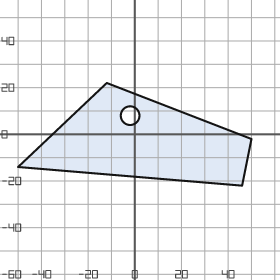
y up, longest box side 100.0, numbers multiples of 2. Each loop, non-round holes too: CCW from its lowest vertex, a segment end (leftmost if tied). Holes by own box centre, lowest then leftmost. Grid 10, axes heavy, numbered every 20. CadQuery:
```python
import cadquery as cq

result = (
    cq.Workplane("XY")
    .moveTo(46.0, -22.0)
    .lineTo(50.0, -2.0)
    .lineTo(-12.0, 22.0)
    .lineTo(-50.0, -14.0)
    .close()
    .moveTo(-2.0, 8.0)
    .circle(4.0)
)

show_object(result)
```